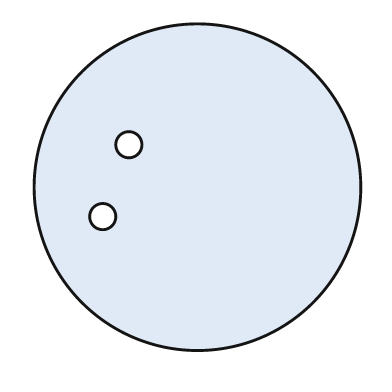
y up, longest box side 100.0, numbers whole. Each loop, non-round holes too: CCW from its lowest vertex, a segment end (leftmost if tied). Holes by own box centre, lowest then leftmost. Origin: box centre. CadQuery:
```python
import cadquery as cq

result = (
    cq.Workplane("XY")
    .moveTo(0.0, 0.0)
    .circle(50.0)
    .moveTo(-29.0, -9.0)
    .circle(4.0)
    .moveTo(-21.0, 13.0)
    .circle(4.0)
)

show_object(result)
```